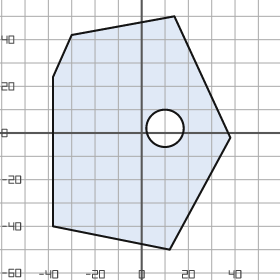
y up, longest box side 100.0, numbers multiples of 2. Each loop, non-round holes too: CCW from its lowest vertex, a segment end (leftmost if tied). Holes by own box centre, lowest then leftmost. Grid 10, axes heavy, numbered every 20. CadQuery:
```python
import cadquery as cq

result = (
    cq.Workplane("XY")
    .moveTo(12.0, -50.0)
    .lineTo(38.0, -2.0)
    .lineTo(14.0, 50.0)
    .lineTo(-30.0, 42.0)
    .lineTo(-38.0, 24.0)
    .lineTo(-38.0, -40.0)
    .close()
    .moveTo(10.0, 2.0)
    .circle(8.0)
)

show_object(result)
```